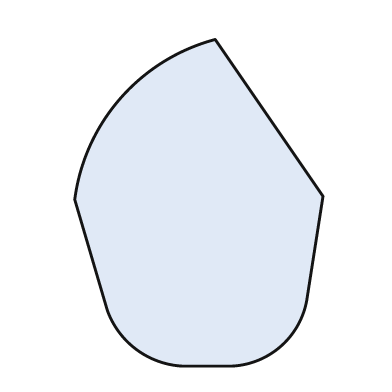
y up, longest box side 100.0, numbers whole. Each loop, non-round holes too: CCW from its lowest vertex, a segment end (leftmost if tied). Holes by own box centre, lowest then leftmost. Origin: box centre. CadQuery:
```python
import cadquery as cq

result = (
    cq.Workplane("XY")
    .moveTo(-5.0, -50.0)
    .lineTo(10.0, -50.0)
    .threePointArc((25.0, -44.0), (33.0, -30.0))
    .lineTo(38.0, 2.0)
    .lineTo(5.0, 50.0)
    .threePointArc((-24.0, 32.0), (-38.0, 1.0))
    .lineTo(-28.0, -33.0)
    .threePointArc((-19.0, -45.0), (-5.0, -50.0))
    .close()
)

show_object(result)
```